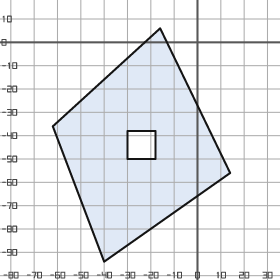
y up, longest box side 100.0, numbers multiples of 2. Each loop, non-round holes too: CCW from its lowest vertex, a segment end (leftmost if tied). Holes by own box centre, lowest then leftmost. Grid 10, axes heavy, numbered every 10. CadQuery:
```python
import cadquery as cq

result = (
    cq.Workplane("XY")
    .moveTo(-40.0, -94.0)
    .lineTo(14.0, -56.0)
    .lineTo(-16.0, 6.0)
    .lineTo(-62.0, -36.0)
    .close()
    .moveTo(-30.0, -50.0)
    .lineTo(-18.0, -50.0)
    .lineTo(-18.0, -38.0)
    .lineTo(-30.0, -38.0)
    .close()
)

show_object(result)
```